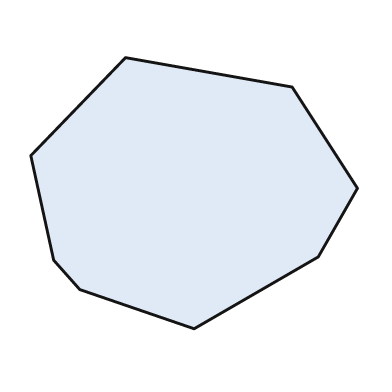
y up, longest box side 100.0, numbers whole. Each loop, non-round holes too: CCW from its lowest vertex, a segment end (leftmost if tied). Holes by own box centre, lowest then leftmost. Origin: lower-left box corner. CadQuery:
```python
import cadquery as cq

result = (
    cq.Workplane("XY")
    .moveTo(50.0, 0.0)
    .lineTo(88.0, 22.0)
    .lineTo(100.0, 43.0)
    .lineTo(80.0, 74.0)
    .lineTo(29.0, 83.0)
    .lineTo(0.0, 53.0)
    .lineTo(7.0, 21.0)
    .lineTo(15.0, 12.0)
    .close()
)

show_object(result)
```